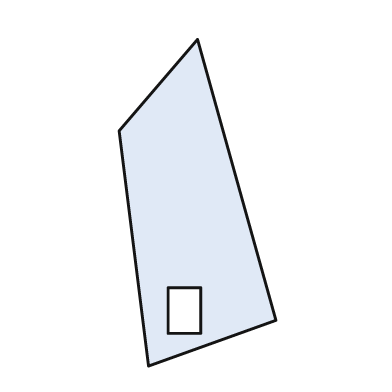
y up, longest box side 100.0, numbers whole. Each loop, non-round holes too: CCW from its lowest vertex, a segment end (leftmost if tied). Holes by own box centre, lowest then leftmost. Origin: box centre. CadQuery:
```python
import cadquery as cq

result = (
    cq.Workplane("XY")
    .moveTo(-15.0, -50.0)
    .lineTo(24.0, -36.0)
    .lineTo(0.0, 50.0)
    .lineTo(-24.0, 22.0)
    .close()
    .moveTo(-9.0, -40.0)
    .lineTo(1.0, -40.0)
    .lineTo(1.0, -26.0)
    .lineTo(-9.0, -26.0)
    .close()
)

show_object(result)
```